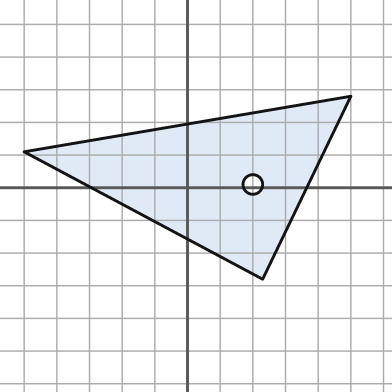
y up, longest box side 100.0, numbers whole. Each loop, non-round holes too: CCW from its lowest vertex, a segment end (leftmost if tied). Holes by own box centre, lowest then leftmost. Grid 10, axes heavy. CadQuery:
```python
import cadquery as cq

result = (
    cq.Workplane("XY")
    .moveTo(23.0, -28.0)
    .lineTo(50.0, 28.0)
    .lineTo(-50.0, 11.0)
    .close()
    .moveTo(20.0, 1.0)
    .circle(3.0)
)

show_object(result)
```